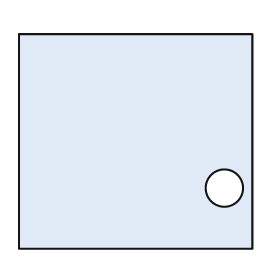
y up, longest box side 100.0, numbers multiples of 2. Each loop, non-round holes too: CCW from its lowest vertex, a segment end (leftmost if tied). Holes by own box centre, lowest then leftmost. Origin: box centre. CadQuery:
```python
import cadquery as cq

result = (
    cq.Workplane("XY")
    .moveTo(-50.0, -46.0)
    .lineTo(50.0, -46.0)
    .lineTo(50.0, 46.0)
    .lineTo(-50.0, 46.0)
    .close()
    .moveTo(38.0, -20.0)
    .circle(8.0)
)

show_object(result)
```